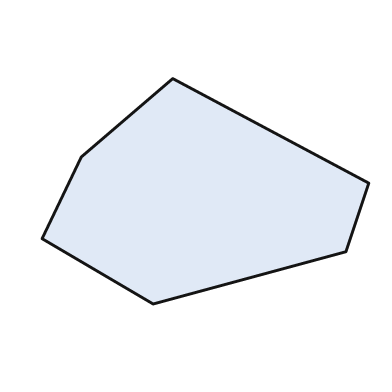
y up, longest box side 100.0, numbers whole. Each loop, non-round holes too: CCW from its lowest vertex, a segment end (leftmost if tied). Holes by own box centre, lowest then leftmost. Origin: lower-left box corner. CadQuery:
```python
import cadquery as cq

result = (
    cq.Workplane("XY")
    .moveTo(34.0, 0.0)
    .lineTo(93.0, 16.0)
    .lineTo(100.0, 37.0)
    .lineTo(40.0, 69.0)
    .lineTo(12.0, 45.0)
    .lineTo(0.0, 20.0)
    .close()
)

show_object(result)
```